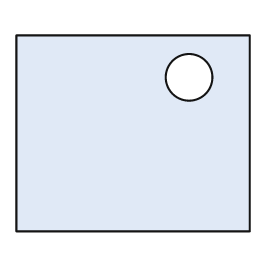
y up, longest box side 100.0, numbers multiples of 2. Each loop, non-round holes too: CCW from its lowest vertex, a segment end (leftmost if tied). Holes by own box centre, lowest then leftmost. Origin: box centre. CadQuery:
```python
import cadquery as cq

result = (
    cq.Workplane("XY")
    .moveTo(-50.0, -42.0)
    .lineTo(50.0, -42.0)
    .lineTo(50.0, 42.0)
    .lineTo(-50.0, 42.0)
    .close()
    .moveTo(24.0, 24.0)
    .circle(10.0)
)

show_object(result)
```